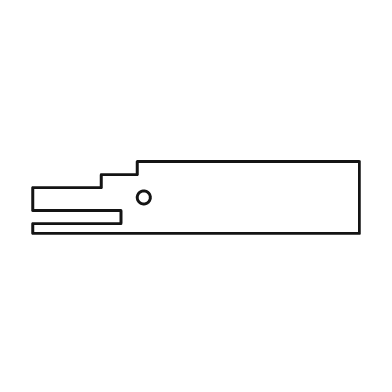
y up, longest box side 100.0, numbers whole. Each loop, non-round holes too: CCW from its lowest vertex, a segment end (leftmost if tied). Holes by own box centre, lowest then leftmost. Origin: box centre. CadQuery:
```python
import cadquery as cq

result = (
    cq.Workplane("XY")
    .moveTo(-50.0, -11.0)
    .lineTo(50.0, -11.0)
    .lineTo(50.0, 11.0)
    .lineTo(-18.0, 11.0)
    .lineTo(-18.0, 7.0)
    .lineTo(-29.0, 7.0)
    .lineTo(-29.0, 3.0)
    .lineTo(-50.0, 3.0)
    .lineTo(-50.0, -4.0)
    .lineTo(-23.0, -4.0)
    .lineTo(-23.0, -8.0)
    .lineTo(-50.0, -8.0)
    .close()
    .moveTo(-16.0, 0.0)
    .circle(2.0)
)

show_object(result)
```